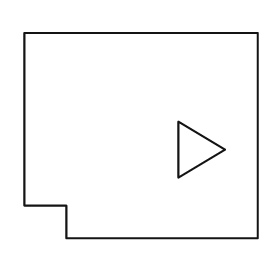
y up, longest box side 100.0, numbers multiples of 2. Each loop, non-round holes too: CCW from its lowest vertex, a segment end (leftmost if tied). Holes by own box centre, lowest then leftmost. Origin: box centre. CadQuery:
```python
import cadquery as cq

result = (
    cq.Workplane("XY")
    .moveTo(-32.0, -44.0)
    .lineTo(50.0, -44.0)
    .lineTo(50.0, 44.0)
    .lineTo(-50.0, 44.0)
    .lineTo(-50.0, -30.0)
    .lineTo(-32.0, -30.0)
    .close()
    .moveTo(16.0, -18.0)
    .lineTo(36.0, -6.0)
    .lineTo(16.0, 6.0)
    .close()
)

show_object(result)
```